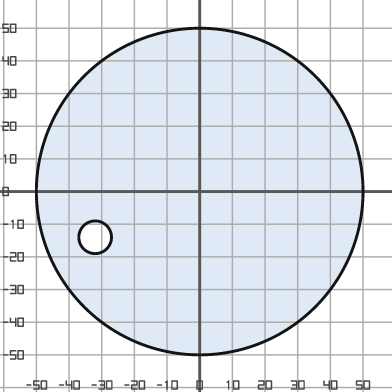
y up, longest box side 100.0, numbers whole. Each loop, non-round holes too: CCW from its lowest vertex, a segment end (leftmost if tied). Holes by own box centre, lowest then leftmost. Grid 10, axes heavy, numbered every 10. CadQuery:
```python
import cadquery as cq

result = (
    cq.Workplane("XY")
    .moveTo(0.0, 0.0)
    .circle(50.0)
    .moveTo(-32.0, -14.0)
    .circle(5.0)
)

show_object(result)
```